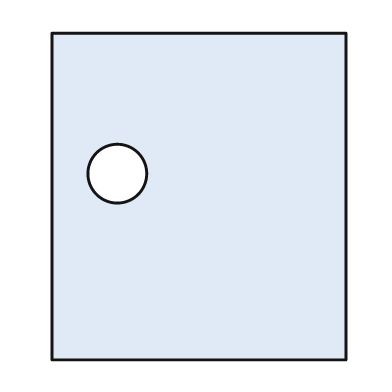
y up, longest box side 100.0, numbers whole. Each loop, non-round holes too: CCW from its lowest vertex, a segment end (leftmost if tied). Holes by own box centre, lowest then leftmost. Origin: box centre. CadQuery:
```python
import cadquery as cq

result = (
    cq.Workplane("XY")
    .moveTo(-45.0, -50.0)
    .lineTo(45.0, -50.0)
    .lineTo(45.0, 50.0)
    .lineTo(-45.0, 50.0)
    .close()
    .moveTo(-25.0, 7.0)
    .circle(9.0)
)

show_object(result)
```